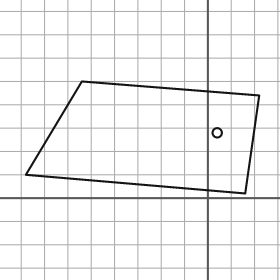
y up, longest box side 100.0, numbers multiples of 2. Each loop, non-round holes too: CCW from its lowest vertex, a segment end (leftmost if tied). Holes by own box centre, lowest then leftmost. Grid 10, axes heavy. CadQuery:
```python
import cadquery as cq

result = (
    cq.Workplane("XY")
    .moveTo(16.0, 2.0)
    .lineTo(22.0, 44.0)
    .lineTo(-54.0, 50.0)
    .lineTo(-78.0, 10.0)
    .close()
    .moveTo(4.0, 28.0)
    .circle(2.0)
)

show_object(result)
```